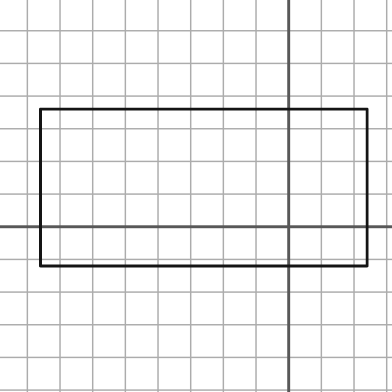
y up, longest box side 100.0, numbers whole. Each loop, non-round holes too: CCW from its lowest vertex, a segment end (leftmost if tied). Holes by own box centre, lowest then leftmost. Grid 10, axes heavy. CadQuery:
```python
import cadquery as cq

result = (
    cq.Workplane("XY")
    .moveTo(-76.0, -12.0)
    .lineTo(24.0, -12.0)
    .lineTo(24.0, 36.0)
    .lineTo(-76.0, 36.0)
    .close()
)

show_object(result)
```